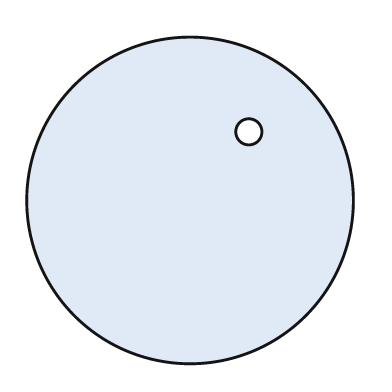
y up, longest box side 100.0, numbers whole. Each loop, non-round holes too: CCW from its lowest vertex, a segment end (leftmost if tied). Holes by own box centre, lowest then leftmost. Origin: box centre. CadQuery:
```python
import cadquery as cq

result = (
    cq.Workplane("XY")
    .moveTo(0.0, 0.0)
    .circle(50.0)
    .moveTo(18.0, 21.0)
    .circle(4.0)
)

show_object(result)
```